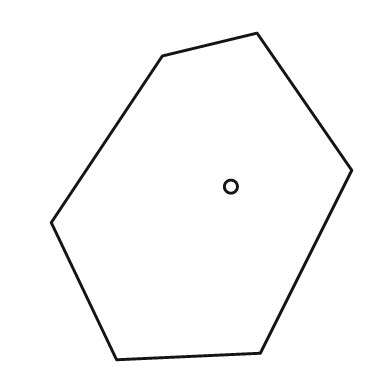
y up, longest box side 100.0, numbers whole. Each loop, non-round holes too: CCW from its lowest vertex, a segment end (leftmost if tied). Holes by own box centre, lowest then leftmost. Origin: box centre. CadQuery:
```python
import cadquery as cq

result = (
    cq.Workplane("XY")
    .moveTo(-26.0, -50.0)
    .lineTo(18.0, -48.0)
    .lineTo(46.0, 8.0)
    .lineTo(17.0, 50.0)
    .lineTo(-12.0, 43.0)
    .lineTo(-46.0, -8.0)
    .close()
    .moveTo(9.0, 3.0)
    .circle(2.0)
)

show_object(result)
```